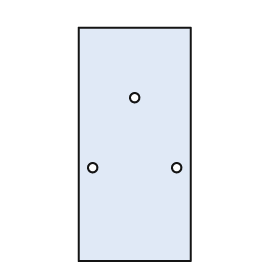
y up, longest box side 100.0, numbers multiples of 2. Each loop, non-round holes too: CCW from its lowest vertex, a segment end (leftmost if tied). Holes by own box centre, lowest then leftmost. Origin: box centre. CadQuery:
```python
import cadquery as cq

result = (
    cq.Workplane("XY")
    .moveTo(-24.0, -50.0)
    .lineTo(24.0, -50.0)
    .lineTo(24.0, 50.0)
    .lineTo(-24.0, 50.0)
    .close()
    .moveTo(-18.0, -10.0)
    .circle(2.0)
    .moveTo(18.0, -10.0)
    .circle(2.0)
    .moveTo(0.0, 20.0)
    .circle(2.0)
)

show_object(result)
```